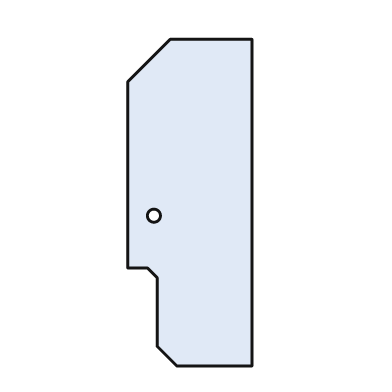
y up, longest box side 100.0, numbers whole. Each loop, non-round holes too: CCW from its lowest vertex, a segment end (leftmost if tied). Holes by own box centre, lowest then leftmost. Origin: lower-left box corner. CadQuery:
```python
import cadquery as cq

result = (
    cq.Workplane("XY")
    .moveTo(15.0, 0.0)
    .lineTo(38.0, 0.0)
    .lineTo(38.0, 100.0)
    .lineTo(13.0, 100.0)
    .lineTo(0.0, 87.0)
    .lineTo(0.0, 30.0)
    .lineTo(6.0, 30.0)
    .lineTo(9.0, 27.0)
    .lineTo(9.0, 6.0)
    .close()
    .moveTo(8.0, 46.0)
    .circle(2.0)
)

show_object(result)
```